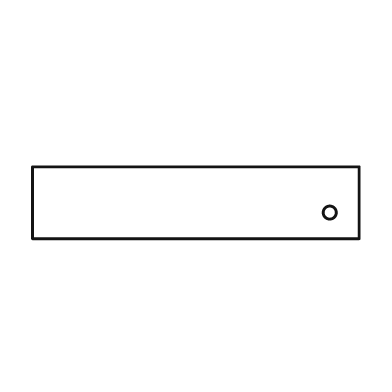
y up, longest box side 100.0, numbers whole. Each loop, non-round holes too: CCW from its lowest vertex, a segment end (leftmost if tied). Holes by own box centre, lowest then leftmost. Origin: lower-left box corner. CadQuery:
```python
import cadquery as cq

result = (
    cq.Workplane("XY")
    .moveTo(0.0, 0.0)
    .lineTo(100.0, 0.0)
    .lineTo(100.0, 22.0)
    .lineTo(0.0, 22.0)
    .close()
    .moveTo(91.0, 8.0)
    .circle(2.0)
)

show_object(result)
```